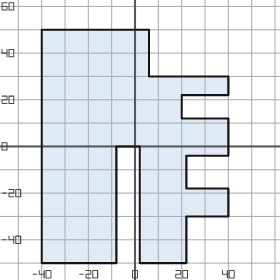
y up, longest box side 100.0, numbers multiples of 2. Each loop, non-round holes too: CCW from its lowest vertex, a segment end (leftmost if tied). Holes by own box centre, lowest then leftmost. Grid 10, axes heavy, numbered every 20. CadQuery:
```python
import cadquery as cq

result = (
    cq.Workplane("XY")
    .moveTo(-40.0, -50.0)
    .lineTo(-8.0, -50.0)
    .lineTo(-8.0, 0.0)
    .lineTo(2.0, 0.0)
    .lineTo(2.0, -50.0)
    .lineTo(22.0, -50.0)
    .lineTo(22.0, -30.0)
    .lineTo(40.0, -30.0)
    .lineTo(40.0, -18.0)
    .lineTo(22.0, -18.0)
    .lineTo(22.0, -4.0)
    .lineTo(40.0, -4.0)
    .lineTo(40.0, 12.0)
    .lineTo(20.0, 12.0)
    .lineTo(20.0, 22.0)
    .lineTo(40.0, 22.0)
    .lineTo(40.0, 30.0)
    .lineTo(6.0, 30.0)
    .lineTo(6.0, 50.0)
    .lineTo(-40.0, 50.0)
    .close()
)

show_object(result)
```